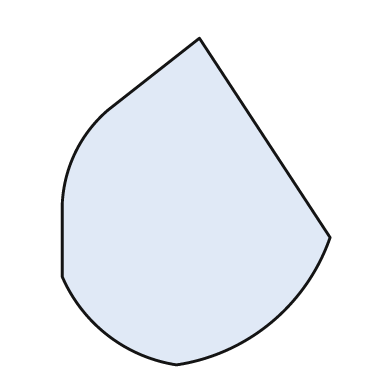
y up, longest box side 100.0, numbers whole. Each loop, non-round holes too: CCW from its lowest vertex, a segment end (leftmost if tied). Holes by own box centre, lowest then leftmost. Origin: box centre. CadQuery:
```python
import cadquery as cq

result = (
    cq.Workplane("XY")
    .moveTo(-6.0, -50.0)
    .threePointArc((23.0, -37.0), (41.0, -11.0))
    .lineTo(1.0, 50.0)
    .lineTo(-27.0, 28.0)
    .threePointArc((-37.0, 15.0), (-41.0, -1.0))
    .lineTo(-41.0, -23.0)
    .threePointArc((-27.0, -41.0), (-6.0, -50.0))
    .close()
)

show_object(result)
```